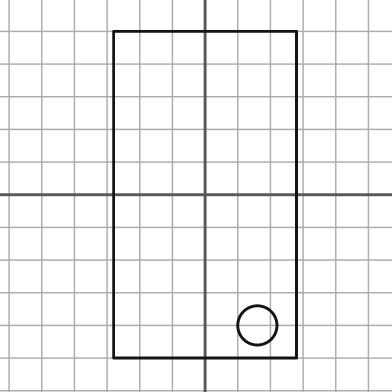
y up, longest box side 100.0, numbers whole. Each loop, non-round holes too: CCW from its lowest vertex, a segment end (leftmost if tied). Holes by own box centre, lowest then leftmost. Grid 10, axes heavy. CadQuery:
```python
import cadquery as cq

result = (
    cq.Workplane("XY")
    .moveTo(-28.0, -50.0)
    .lineTo(28.0, -50.0)
    .lineTo(28.0, 50.0)
    .lineTo(-28.0, 50.0)
    .close()
    .moveTo(16.0, -40.0)
    .circle(6.0)
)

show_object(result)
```